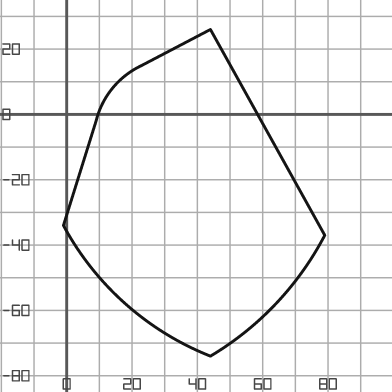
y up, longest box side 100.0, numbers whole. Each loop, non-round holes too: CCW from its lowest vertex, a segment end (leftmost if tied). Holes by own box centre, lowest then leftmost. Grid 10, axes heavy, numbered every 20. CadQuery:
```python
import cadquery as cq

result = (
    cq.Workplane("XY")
    .moveTo(44.0, -74.0)
    .threePointArc((64.0, -58.0), (79.0, -37.0))
    .lineTo(44.0, 26.0)
    .lineTo(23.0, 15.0)
    .threePointArc((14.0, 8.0), (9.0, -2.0))
    .lineTo(-1.0, -34.0)
    .threePointArc((18.0, -58.0), (44.0, -74.0))
    .close()
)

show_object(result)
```